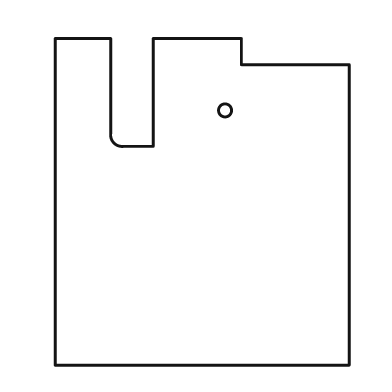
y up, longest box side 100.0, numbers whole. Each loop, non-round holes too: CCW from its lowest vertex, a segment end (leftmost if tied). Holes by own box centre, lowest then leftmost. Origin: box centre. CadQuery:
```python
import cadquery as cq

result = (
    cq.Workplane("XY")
    .moveTo(-45.0, -50.0)
    .lineTo(45.0, -50.0)
    .lineTo(45.0, 42.0)
    .lineTo(12.0, 42.0)
    .lineTo(12.0, 50.0)
    .lineTo(-15.0, 50.0)
    .lineTo(-15.0, 17.0)
    .lineTo(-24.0, 17.0)
    .threePointArc((-27.0, 18.0), (-28.0, 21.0))
    .lineTo(-28.0, 50.0)
    .lineTo(-45.0, 50.0)
    .close()
    .moveTo(7.0, 28.0)
    .circle(2.0)
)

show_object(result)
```